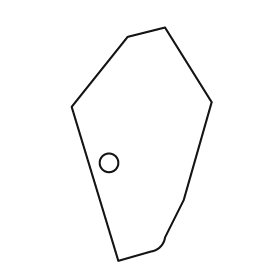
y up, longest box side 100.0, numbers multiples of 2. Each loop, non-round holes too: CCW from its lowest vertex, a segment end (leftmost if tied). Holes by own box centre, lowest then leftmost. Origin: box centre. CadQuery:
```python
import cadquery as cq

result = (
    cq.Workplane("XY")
    .moveTo(-10.0, -50.0)
    .lineTo(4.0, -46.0)
    .threePointArc((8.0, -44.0), (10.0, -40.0))
    .lineTo(18.0, -24.0)
    .lineTo(30.0, 18.0)
    .lineTo(10.0, 50.0)
    .lineTo(-6.0, 46.0)
    .lineTo(-30.0, 16.0)
    .close()
    .moveTo(-14.0, -8.0)
    .circle(4.0)
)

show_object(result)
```